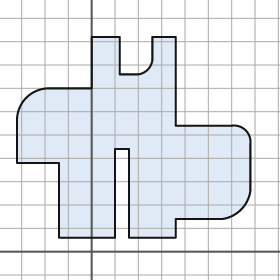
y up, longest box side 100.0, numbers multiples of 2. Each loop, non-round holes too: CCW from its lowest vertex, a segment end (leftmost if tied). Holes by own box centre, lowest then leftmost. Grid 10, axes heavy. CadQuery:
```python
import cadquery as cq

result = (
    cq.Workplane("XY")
    .moveTo(-14.0, 6.0)
    .lineTo(10.0, 6.0)
    .lineTo(10.0, 44.0)
    .lineTo(16.0, 44.0)
    .lineTo(16.0, 6.0)
    .lineTo(36.0, 6.0)
    .lineTo(36.0, 14.0)
    .lineTo(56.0, 14.0)
    .threePointArc((64.0, 18.0), (68.0, 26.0))
    .lineTo(68.0, 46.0)
    .threePointArc((66.0, 52.0), (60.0, 54.0))
    .lineTo(36.0, 54.0)
    .lineTo(36.0, 92.0)
    .lineTo(26.0, 92.0)
    .lineTo(26.0, 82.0)
    .threePointArc((24.0, 78.0), (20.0, 76.0))
    .lineTo(12.0, 76.0)
    .lineTo(12.0, 92.0)
    .lineTo(0.0, 92.0)
    .lineTo(0.0, 70.0)
    .lineTo(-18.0, 70.0)
    .threePointArc((-28.0, 66.0), (-32.0, 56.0))
    .lineTo(-32.0, 38.0)
    .lineTo(-14.0, 38.0)
    .close()
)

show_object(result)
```